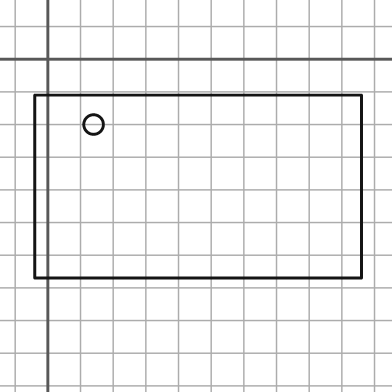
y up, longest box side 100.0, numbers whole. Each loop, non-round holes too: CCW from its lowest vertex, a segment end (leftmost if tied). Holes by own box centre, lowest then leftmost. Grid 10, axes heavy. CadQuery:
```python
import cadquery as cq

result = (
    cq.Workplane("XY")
    .moveTo(-4.0, -67.0)
    .lineTo(96.0, -67.0)
    .lineTo(96.0, -11.0)
    .lineTo(-4.0, -11.0)
    .close()
    .moveTo(14.0, -20.0)
    .circle(3.0)
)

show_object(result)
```